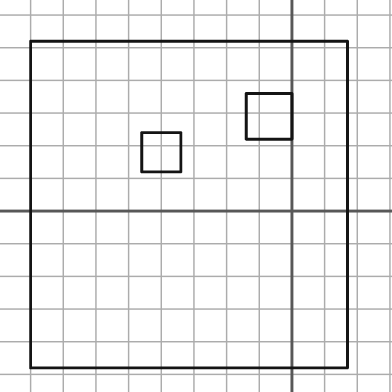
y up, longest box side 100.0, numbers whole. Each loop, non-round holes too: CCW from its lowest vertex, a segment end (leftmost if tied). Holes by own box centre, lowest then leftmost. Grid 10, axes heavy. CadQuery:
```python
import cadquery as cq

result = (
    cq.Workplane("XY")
    .moveTo(-80.0, -48.0)
    .lineTo(17.0, -48.0)
    .lineTo(17.0, 52.0)
    .lineTo(-80.0, 52.0)
    .close()
    .moveTo(-46.0, 12.0)
    .lineTo(-34.0, 12.0)
    .lineTo(-34.0, 24.0)
    .lineTo(-46.0, 24.0)
    .close()
    .moveTo(-14.0, 22.0)
    .lineTo(0.0, 22.0)
    .lineTo(0.0, 36.0)
    .lineTo(-14.0, 36.0)
    .close()
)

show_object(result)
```